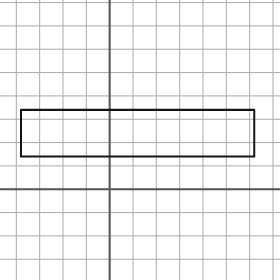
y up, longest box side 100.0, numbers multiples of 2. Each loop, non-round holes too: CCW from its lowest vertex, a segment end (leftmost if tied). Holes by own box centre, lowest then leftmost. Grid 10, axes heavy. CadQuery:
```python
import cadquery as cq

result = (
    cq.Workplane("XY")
    .moveTo(-38.0, 14.0)
    .lineTo(62.0, 14.0)
    .lineTo(62.0, 34.0)
    .lineTo(-38.0, 34.0)
    .close()
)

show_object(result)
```